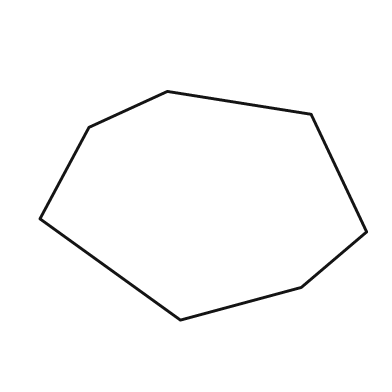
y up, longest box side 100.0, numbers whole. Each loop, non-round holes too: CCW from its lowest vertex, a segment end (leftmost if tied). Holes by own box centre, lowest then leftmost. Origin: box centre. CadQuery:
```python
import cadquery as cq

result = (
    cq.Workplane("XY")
    .moveTo(-7.0, -35.0)
    .lineTo(30.0, -25.0)
    .lineTo(50.0, -8.0)
    .lineTo(33.0, 28.0)
    .lineTo(-11.0, 35.0)
    .lineTo(-35.0, 24.0)
    .lineTo(-50.0, -4.0)
    .close()
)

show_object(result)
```